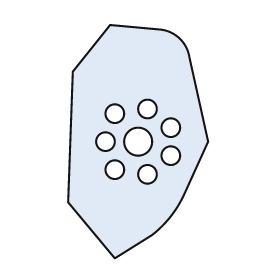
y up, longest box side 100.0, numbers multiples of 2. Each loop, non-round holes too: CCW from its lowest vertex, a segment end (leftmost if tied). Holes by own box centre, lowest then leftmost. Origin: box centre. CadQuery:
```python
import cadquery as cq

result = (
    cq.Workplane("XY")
    .moveTo(-10.0, -50.0)
    .lineTo(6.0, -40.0)
    .threePointArc((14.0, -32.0), (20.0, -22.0))
    .lineTo(30.0, 0.0)
    .lineTo(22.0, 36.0)
    .threePointArc((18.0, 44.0), (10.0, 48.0))
    .lineTo(-12.0, 50.0)
    .lineTo(-28.0, 30.0)
    .lineTo(-30.0, -26.0)
    .close()
    .moveTo(4.0, -14.0)
    .circle(4.0)
    .moveTo(-10.0, -12.0)
    .circle(4.0)
    .moveTo(14.0, -6.0)
    .circle(4.0)
    .moveTo(-14.0, 0.0)
    .circle(4.0)
    .moveTo(0.0, 0.0)
    .circle(6.0)
    .moveTo(14.0, 6.0)
    .circle(4.0)
    .moveTo(-10.0, 12.0)
    .circle(4.0)
    .moveTo(4.0, 14.0)
    .circle(4.0)
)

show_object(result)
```